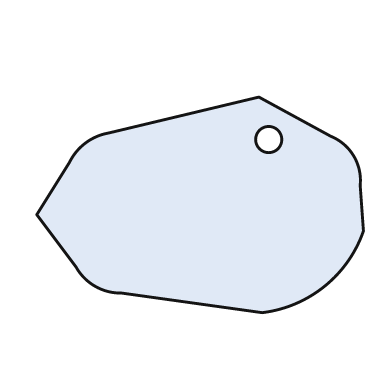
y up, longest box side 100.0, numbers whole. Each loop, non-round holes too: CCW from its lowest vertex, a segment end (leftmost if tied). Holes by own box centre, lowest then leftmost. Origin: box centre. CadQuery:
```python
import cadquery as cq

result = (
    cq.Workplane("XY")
    .moveTo(19.0, -33.0)
    .threePointArc((38.0, -25.0), (50.0, -8.0))
    .lineTo(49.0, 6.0)
    .threePointArc((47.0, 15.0), (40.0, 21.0))
    .lineTo(18.0, 33.0)
    .lineTo(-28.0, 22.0)
    .threePointArc((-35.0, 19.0), (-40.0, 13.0))
    .lineTo(-50.0, -3.0)
    .lineTo(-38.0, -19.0)
    .threePointArc((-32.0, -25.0), (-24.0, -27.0))
    .close()
    .moveTo(21.0, 20.0)
    .circle(4.0)
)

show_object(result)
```